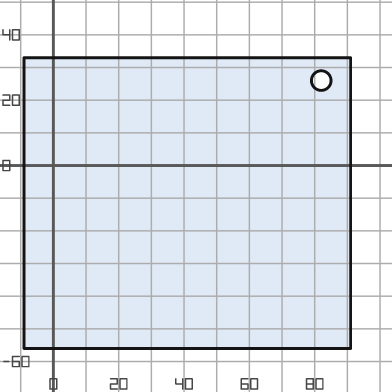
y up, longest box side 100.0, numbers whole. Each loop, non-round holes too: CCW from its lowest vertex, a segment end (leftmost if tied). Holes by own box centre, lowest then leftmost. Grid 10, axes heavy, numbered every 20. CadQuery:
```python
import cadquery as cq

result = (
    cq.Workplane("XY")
    .moveTo(-9.0, -56.0)
    .lineTo(91.0, -56.0)
    .lineTo(91.0, 33.0)
    .lineTo(-9.0, 33.0)
    .close()
    .moveTo(82.0, 26.0)
    .circle(3.0)
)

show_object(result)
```